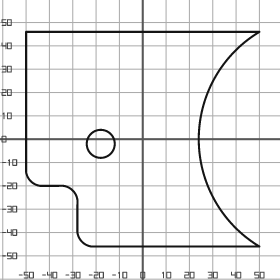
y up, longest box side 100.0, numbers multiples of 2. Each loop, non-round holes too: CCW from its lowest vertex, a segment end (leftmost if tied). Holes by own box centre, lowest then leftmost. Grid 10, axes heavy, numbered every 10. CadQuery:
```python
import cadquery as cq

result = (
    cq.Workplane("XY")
    .moveTo(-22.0, -46.0)
    .lineTo(50.0, -46.0)
    .threePointArc((24.0, 0.0), (50.0, 46.0))
    .lineTo(-50.0, 46.0)
    .lineTo(-50.0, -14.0)
    .threePointArc((-48.0, -18.0), (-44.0, -20.0))
    .lineTo(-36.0, -20.0)
    .threePointArc((-30.0, -22.0), (-28.0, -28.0))
    .lineTo(-28.0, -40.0)
    .threePointArc((-26.0, -44.0), (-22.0, -46.0))
    .close()
    .moveTo(-18.0, -2.0)
    .circle(6.0)
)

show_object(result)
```